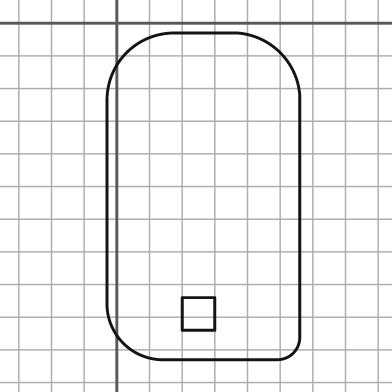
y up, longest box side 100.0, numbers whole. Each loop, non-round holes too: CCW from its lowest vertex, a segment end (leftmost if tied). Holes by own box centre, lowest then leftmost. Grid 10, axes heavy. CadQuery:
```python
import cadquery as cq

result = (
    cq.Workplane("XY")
    .moveTo(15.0, -103.0)
    .lineTo(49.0, -103.0)
    .threePointArc((54.0, -101.0), (56.0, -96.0))
    .lineTo(56.0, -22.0)
    .threePointArc((50.0, -9.0), (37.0, -3.0))
    .lineTo(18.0, -3.0)
    .threePointArc((3.0, -9.0), (-3.0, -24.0))
    .lineTo(-3.0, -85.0)
    .threePointArc((2.0, -98.0), (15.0, -103.0))
    .close()
    .moveTo(20.0, -94.0)
    .lineTo(30.0, -94.0)
    .lineTo(30.0, -84.0)
    .lineTo(20.0, -84.0)
    .close()
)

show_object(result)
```